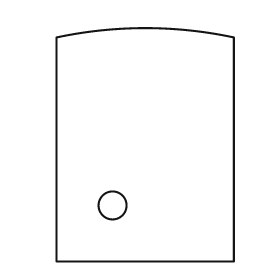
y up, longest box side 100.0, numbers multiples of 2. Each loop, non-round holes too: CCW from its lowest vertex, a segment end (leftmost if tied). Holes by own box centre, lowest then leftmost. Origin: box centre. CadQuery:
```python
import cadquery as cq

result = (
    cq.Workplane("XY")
    .moveTo(-38.0, -50.0)
    .lineTo(38.0, -50.0)
    .lineTo(38.0, 46.0)
    .threePointArc((0.0, 50.0), (-38.0, 46.0))
    .close()
    .moveTo(-14.0, -26.0)
    .circle(6.0)
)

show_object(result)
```